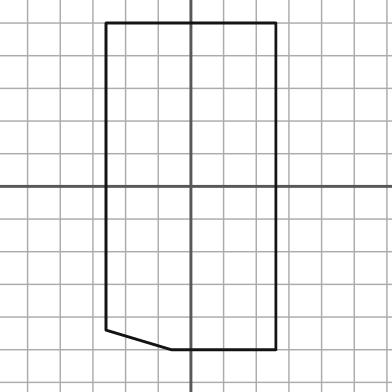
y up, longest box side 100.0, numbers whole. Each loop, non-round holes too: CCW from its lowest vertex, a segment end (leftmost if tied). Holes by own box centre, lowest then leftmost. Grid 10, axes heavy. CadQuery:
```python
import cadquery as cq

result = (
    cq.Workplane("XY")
    .moveTo(-6.0, -50.0)
    .lineTo(26.0, -50.0)
    .lineTo(26.0, 50.0)
    .lineTo(-26.0, 50.0)
    .lineTo(-26.0, -44.0)
    .close()
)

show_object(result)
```